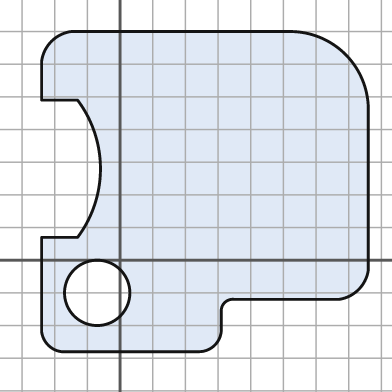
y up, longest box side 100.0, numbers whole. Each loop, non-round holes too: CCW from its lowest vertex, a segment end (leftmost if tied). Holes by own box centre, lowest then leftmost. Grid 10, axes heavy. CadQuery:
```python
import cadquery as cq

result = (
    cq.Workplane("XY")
    .moveTo(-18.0, -28.0)
    .lineTo(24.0, -28.0)
    .threePointArc((29.0, -26.0), (31.0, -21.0))
    .lineTo(31.0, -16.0)
    .threePointArc((32.0, -13.0), (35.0, -12.0))
    .lineTo(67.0, -12.0)
    .threePointArc((73.0, -9.0), (76.0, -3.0))
    .lineTo(76.0, 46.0)
    .threePointArc((69.0, 63.0), (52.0, 70.0))
    .lineTo(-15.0, 70.0)
    .threePointArc((-21.0, 67.0), (-24.0, 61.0))
    .lineTo(-24.0, 49.0)
    .lineTo(-13.0, 49.0)
    .threePointArc((-6.0, 28.0), (-13.0, 7.0))
    .lineTo(-24.0, 7.0)
    .lineTo(-24.0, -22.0)
    .threePointArc((-22.0, -26.0), (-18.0, -28.0))
    .close()
    .moveTo(-7.0, -10.0)
    .circle(10.0)
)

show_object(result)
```